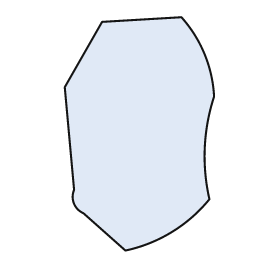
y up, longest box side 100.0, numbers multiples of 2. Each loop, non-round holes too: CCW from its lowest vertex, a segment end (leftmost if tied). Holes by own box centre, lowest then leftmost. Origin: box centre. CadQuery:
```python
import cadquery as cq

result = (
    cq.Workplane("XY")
    .moveTo(-6.0, -50.0)
    .threePointArc((14.0, -42.0), (30.0, -28.0))
    .threePointArc((28.0, -6.0), (32.0, 16.0))
    .threePointArc((28.0, 34.0), (18.0, 50.0))
    .lineTo(-16.0, 48.0)
    .lineTo(-32.0, 20.0)
    .lineTo(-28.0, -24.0)
    .threePointArc((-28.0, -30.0), (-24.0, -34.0))
    .close()
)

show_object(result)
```